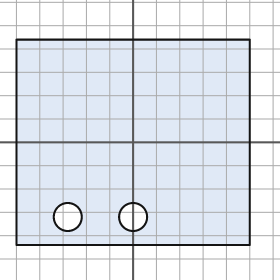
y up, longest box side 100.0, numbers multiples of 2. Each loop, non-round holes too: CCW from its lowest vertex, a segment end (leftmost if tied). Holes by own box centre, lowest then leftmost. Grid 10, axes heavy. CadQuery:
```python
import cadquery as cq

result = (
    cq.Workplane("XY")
    .moveTo(-50.0, -44.0)
    .lineTo(50.0, -44.0)
    .lineTo(50.0, 44.0)
    .lineTo(-50.0, 44.0)
    .close()
    .moveTo(-28.0, -32.0)
    .circle(6.0)
    .moveTo(0.0, -32.0)
    .circle(6.0)
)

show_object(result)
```